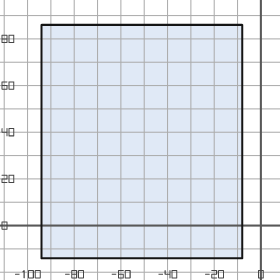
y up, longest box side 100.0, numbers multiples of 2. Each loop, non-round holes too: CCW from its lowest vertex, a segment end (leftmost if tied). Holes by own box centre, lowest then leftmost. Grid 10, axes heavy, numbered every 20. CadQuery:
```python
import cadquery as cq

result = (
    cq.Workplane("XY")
    .moveTo(-94.0, -14.0)
    .lineTo(-8.0, -14.0)
    .lineTo(-8.0, 86.0)
    .lineTo(-94.0, 86.0)
    .close()
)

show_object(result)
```